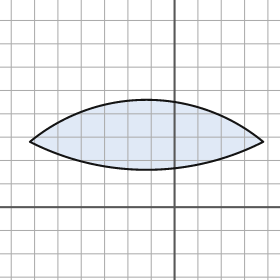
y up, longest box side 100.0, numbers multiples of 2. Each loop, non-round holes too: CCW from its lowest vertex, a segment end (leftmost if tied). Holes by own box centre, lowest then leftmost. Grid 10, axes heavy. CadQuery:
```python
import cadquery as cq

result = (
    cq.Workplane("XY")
    .moveTo(-62.0, 28.0)
    .threePointArc((-12.0, 16.0), (38.0, 28.0))
    .threePointArc((-12.0, 46.0), (-62.0, 28.0))
    .close()
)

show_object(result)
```